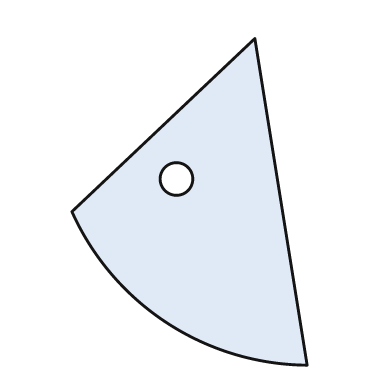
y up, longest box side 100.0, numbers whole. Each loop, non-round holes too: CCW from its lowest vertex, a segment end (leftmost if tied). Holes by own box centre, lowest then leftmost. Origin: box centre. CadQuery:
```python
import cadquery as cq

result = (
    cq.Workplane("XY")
    .moveTo(36.0, -50.0)
    .lineTo(20.0, 50.0)
    .lineTo(-36.0, -3.0)
    .threePointArc((-7.0, -37.0), (36.0, -50.0))
    .close()
    .moveTo(-4.0, 7.0)
    .circle(5.0)
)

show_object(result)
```